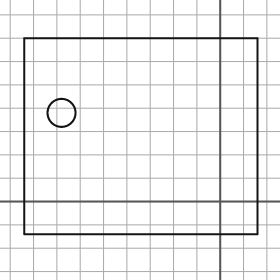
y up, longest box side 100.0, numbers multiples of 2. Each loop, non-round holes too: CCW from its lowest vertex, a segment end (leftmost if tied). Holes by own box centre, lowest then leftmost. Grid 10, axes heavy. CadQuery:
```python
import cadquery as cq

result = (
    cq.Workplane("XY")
    .moveTo(-84.0, -14.0)
    .lineTo(16.0, -14.0)
    .lineTo(16.0, 70.0)
    .lineTo(-84.0, 70.0)
    .close()
    .moveTo(-68.0, 38.0)
    .circle(6.0)
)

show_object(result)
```